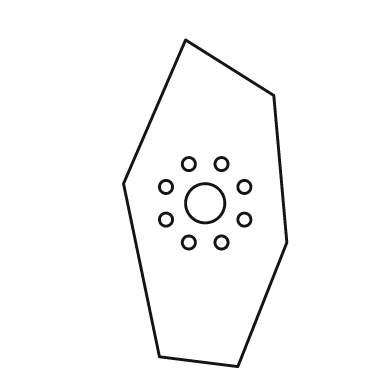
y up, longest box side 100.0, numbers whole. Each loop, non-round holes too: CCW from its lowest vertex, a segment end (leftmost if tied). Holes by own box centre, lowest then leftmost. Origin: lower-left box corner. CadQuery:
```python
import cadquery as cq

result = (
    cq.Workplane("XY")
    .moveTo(35.0, 0.0)
    .lineTo(50.0, 38.0)
    .lineTo(46.0, 83.0)
    .lineTo(19.0, 100.0)
    .lineTo(0.0, 56.0)
    .lineTo(11.0, 3.0)
    .close()
    .moveTo(20.0, 38.0)
    .circle(2.0)
    .moveTo(30.0, 38.0)
    .circle(2.0)
    .moveTo(13.0, 45.0)
    .circle(2.0)
    .moveTo(37.0, 45.0)
    .circle(2.0)
    .moveTo(25.0, 50.0)
    .circle(6.0)
    .moveTo(13.0, 55.0)
    .circle(2.0)
    .moveTo(37.0, 55.0)
    .circle(2.0)
    .moveTo(20.0, 62.0)
    .circle(2.0)
    .moveTo(30.0, 62.0)
    .circle(2.0)
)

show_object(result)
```